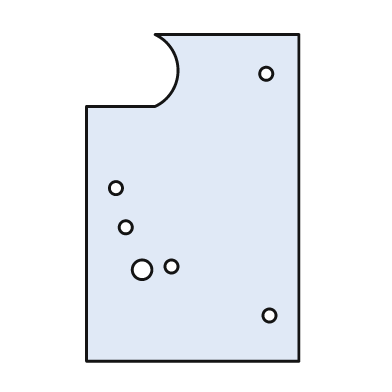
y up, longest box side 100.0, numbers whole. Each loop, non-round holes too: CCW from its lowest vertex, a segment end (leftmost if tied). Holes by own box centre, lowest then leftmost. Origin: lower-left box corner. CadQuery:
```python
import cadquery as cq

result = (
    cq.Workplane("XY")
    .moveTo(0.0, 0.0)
    .lineTo(65.0, 0.0)
    .lineTo(65.0, 100.0)
    .lineTo(21.0, 100.0)
    .threePointArc((28.0, 89.0), (21.0, 78.0))
    .lineTo(0.0, 78.0)
    .close()
    .moveTo(56.0, 14.0)
    .circle(2.0)
    .moveTo(17.0, 28.0)
    .circle(3.0)
    .moveTo(26.0, 29.0)
    .circle(2.0)
    .moveTo(12.0, 41.0)
    .circle(2.0)
    .moveTo(9.0, 53.0)
    .circle(2.0)
    .moveTo(55.0, 88.0)
    .circle(2.0)
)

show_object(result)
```